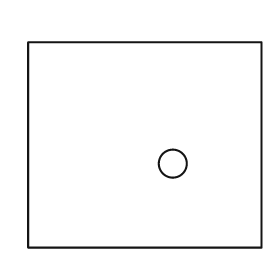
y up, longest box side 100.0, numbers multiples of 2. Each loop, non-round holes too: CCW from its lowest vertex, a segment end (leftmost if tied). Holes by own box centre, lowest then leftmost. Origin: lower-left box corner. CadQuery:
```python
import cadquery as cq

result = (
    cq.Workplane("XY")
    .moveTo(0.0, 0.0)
    .lineTo(100.0, 0.0)
    .lineTo(100.0, 88.0)
    .lineTo(0.0, 88.0)
    .close()
    .moveTo(62.0, 36.0)
    .circle(6.0)
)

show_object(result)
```